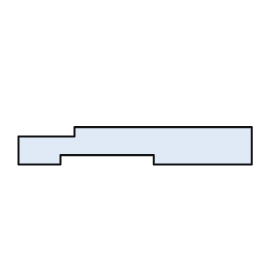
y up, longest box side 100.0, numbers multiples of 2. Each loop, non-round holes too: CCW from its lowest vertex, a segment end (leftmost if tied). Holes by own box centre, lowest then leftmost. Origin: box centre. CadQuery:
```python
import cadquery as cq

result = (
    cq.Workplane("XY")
    .moveTo(-50.0, -8.0)
    .lineTo(-32.0, -8.0)
    .lineTo(-32.0, -4.0)
    .lineTo(8.0, -4.0)
    .lineTo(8.0, -8.0)
    .lineTo(50.0, -8.0)
    .lineTo(50.0, 8.0)
    .lineTo(-26.0, 8.0)
    .lineTo(-26.0, 4.0)
    .lineTo(-50.0, 4.0)
    .close()
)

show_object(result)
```